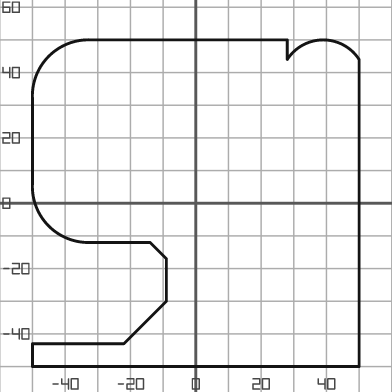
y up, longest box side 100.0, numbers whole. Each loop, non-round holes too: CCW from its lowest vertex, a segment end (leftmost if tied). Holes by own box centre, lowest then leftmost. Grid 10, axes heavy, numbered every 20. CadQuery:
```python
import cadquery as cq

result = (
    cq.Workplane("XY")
    .moveTo(-50.0, -50.0)
    .lineTo(50.0, -50.0)
    .lineTo(50.0, 44.0)
    .threePointArc((39.0, 50.0), (28.0, 44.0))
    .lineTo(28.0, 50.0)
    .lineTo(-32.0, 50.0)
    .threePointArc((-45.0, 45.0), (-50.0, 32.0))
    .lineTo(-50.0, 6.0)
    .threePointArc((-45.0, -7.0), (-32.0, -12.0))
    .lineTo(-14.0, -12.0)
    .lineTo(-9.0, -17.0)
    .lineTo(-9.0, -30.0)
    .lineTo(-22.0, -43.0)
    .lineTo(-50.0, -43.0)
    .close()
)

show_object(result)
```